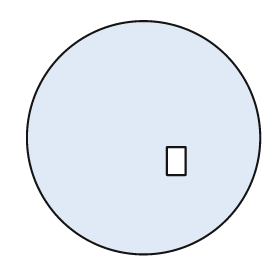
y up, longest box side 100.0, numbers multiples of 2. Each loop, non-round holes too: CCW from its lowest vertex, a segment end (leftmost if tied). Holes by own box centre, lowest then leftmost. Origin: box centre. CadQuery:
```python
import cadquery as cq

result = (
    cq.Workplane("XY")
    .moveTo(0.0, 0.0)
    .circle(50.0)
    .moveTo(10.0, -16.0)
    .lineTo(18.0, -16.0)
    .lineTo(18.0, -4.0)
    .lineTo(10.0, -4.0)
    .close()
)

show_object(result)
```